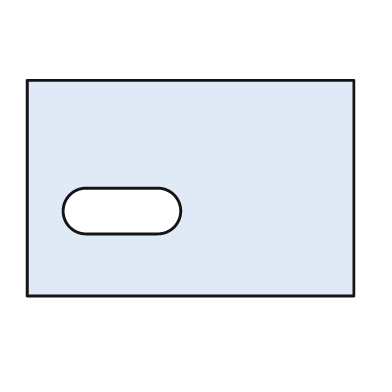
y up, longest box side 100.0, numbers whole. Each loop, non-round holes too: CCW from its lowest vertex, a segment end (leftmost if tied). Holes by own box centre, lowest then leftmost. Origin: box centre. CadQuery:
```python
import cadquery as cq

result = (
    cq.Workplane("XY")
    .moveTo(-50.0, -33.0)
    .lineTo(50.0, -33.0)
    .lineTo(50.0, 33.0)
    .lineTo(-50.0, 33.0)
    .close()
    .moveTo(-32.0, -14.0)
    .lineTo(-10.0, -14.0)
    .threePointArc((-3.0, -7.0), (-10.0, 0.0))
    .lineTo(-32.0, 0.0)
    .threePointArc((-39.0, -7.0), (-32.0, -14.0))
    .close()
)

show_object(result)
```